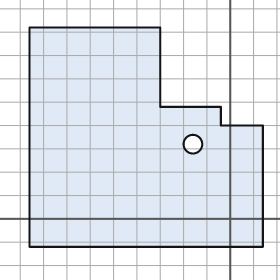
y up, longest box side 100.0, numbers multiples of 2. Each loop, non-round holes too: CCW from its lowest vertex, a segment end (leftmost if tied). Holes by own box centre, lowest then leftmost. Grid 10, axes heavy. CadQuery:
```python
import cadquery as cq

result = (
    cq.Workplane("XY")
    .moveTo(-86.0, -12.0)
    .lineTo(14.0, -12.0)
    .lineTo(14.0, 40.0)
    .lineTo(-4.0, 40.0)
    .lineTo(-4.0, 48.0)
    .lineTo(-30.0, 48.0)
    .lineTo(-30.0, 82.0)
    .lineTo(-86.0, 82.0)
    .close()
    .moveTo(-16.0, 32.0)
    .circle(4.0)
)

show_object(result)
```